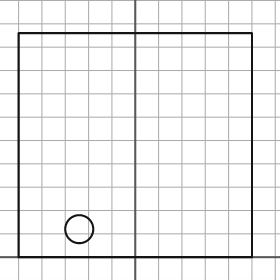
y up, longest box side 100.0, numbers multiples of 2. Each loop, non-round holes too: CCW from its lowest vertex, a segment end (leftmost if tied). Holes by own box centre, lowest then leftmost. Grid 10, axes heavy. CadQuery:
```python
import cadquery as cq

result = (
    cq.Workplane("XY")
    .moveTo(-50.0, 0.0)
    .lineTo(50.0, 0.0)
    .lineTo(50.0, 96.0)
    .lineTo(-50.0, 96.0)
    .close()
    .moveTo(-24.0, 12.0)
    .circle(6.0)
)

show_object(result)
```